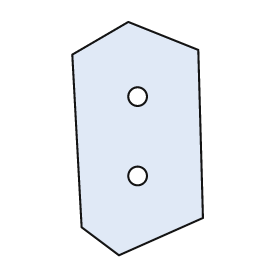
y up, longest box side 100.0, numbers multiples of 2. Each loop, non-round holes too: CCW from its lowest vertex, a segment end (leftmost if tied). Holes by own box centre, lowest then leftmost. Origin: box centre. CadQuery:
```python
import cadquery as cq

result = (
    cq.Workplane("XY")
    .moveTo(-8.0, -50.0)
    .lineTo(28.0, -34.0)
    .lineTo(26.0, 38.0)
    .lineTo(-4.0, 50.0)
    .lineTo(-28.0, 36.0)
    .lineTo(-24.0, -38.0)
    .close()
    .moveTo(0.0, -16.0)
    .circle(4.0)
    .moveTo(0.0, 18.0)
    .circle(4.0)
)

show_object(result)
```